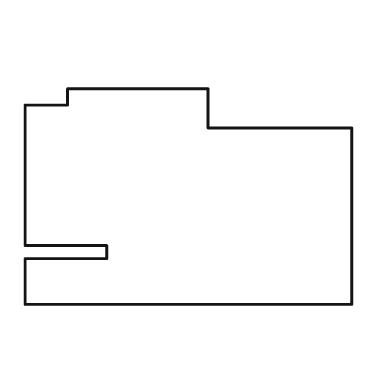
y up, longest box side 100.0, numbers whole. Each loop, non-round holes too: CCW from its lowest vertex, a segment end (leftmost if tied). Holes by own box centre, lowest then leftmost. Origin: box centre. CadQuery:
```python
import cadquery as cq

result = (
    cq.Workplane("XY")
    .moveTo(-50.0, -33.0)
    .lineTo(50.0, -33.0)
    .lineTo(50.0, 21.0)
    .lineTo(6.0, 21.0)
    .lineTo(6.0, 33.0)
    .lineTo(-37.0, 33.0)
    .lineTo(-37.0, 28.0)
    .lineTo(-50.0, 28.0)
    .lineTo(-50.0, -15.0)
    .lineTo(-25.0, -15.0)
    .lineTo(-25.0, -19.0)
    .lineTo(-50.0, -19.0)
    .close()
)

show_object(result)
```